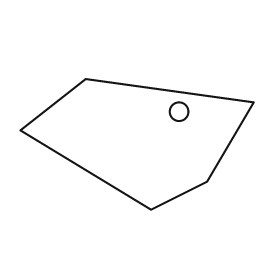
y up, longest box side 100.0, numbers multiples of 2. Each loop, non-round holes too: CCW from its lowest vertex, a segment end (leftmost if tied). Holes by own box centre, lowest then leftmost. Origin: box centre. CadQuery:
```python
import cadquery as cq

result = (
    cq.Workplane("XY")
    .moveTo(6.0, -28.0)
    .lineTo(30.0, -16.0)
    .lineTo(50.0, 18.0)
    .lineTo(-22.0, 28.0)
    .lineTo(-50.0, 6.0)
    .close()
    .moveTo(18.0, 14.0)
    .circle(4.0)
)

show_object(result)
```